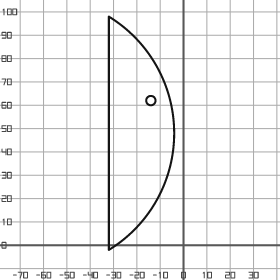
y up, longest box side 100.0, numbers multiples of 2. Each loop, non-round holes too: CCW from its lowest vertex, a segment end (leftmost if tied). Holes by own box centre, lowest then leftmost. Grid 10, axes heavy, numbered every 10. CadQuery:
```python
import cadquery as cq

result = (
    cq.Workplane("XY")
    .moveTo(-32.0, -2.0)
    .threePointArc((-4.0, 48.0), (-32.0, 98.0))
    .close()
    .moveTo(-14.0, 62.0)
    .circle(2.0)
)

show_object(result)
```